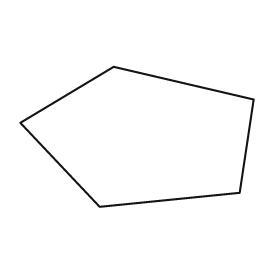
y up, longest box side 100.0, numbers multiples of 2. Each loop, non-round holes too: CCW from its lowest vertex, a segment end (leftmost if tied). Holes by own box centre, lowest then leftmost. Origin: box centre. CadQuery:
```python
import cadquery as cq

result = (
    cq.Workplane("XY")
    .moveTo(-16.0, -30.0)
    .lineTo(44.0, -24.0)
    .lineTo(50.0, 16.0)
    .lineTo(-10.0, 30.0)
    .lineTo(-50.0, 6.0)
    .close()
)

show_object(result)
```